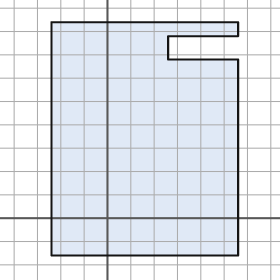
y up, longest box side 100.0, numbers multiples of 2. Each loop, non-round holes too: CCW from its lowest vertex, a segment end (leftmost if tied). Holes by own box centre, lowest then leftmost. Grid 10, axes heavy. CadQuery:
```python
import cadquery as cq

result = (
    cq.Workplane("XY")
    .moveTo(-24.0, -16.0)
    .lineTo(56.0, -16.0)
    .lineTo(56.0, 68.0)
    .lineTo(26.0, 68.0)
    .lineTo(26.0, 78.0)
    .lineTo(56.0, 78.0)
    .lineTo(56.0, 84.0)
    .lineTo(-24.0, 84.0)
    .close()
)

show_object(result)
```